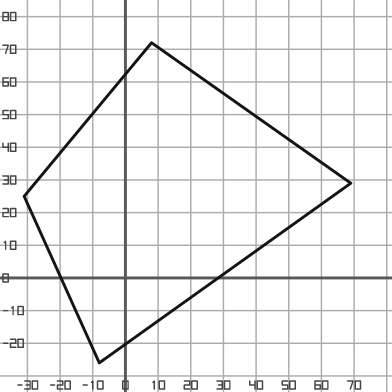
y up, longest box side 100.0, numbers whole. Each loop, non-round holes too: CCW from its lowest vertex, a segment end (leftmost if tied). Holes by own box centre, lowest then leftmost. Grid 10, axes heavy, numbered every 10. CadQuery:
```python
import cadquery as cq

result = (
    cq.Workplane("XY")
    .moveTo(-8.0, -26.0)
    .lineTo(69.0, 29.0)
    .lineTo(8.0, 72.0)
    .lineTo(-31.0, 25.0)
    .close()
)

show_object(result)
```